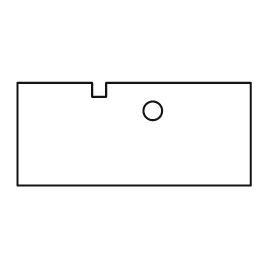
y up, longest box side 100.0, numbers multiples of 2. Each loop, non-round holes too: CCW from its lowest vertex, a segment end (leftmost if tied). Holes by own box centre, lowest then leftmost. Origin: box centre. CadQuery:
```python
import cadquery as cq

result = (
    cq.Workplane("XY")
    .moveTo(-50.0, -22.0)
    .lineTo(50.0, -22.0)
    .lineTo(50.0, 22.0)
    .lineTo(-12.0, 22.0)
    .lineTo(-12.0, 16.0)
    .lineTo(-18.0, 16.0)
    .lineTo(-18.0, 22.0)
    .lineTo(-50.0, 22.0)
    .close()
    .moveTo(8.0, 10.0)
    .circle(4.0)
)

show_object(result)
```